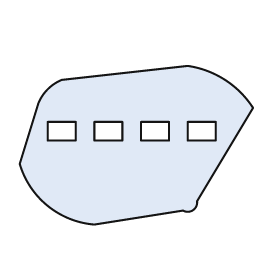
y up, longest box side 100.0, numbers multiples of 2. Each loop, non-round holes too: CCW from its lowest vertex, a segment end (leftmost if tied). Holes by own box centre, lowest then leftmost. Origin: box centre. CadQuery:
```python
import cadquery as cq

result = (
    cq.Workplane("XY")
    .moveTo(-18.0, -34.0)
    .lineTo(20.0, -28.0)
    .threePointArc((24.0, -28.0), (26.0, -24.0))
    .lineTo(50.0, 16.0)
    .threePointArc((38.0, 28.0), (22.0, 34.0))
    .lineTo(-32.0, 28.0)
    .threePointArc((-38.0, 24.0), (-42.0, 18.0))
    .lineTo(-50.0, -8.0)
    .threePointArc((-38.0, -26.0), (-18.0, -34.0))
    .close()
    .moveTo(-38.0, 2.0)
    .lineTo(-26.0, 2.0)
    .lineTo(-26.0, 10.0)
    .lineTo(-38.0, 10.0)
    .close()
    .moveTo(-18.0, 2.0)
    .lineTo(-6.0, 2.0)
    .lineTo(-6.0, 10.0)
    .lineTo(-18.0, 10.0)
    .close()
    .moveTo(2.0, 2.0)
    .lineTo(14.0, 2.0)
    .lineTo(14.0, 10.0)
    .lineTo(2.0, 10.0)
    .close()
    .moveTo(22.0, 2.0)
    .lineTo(34.0, 2.0)
    .lineTo(34.0, 10.0)
    .lineTo(22.0, 10.0)
    .close()
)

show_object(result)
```